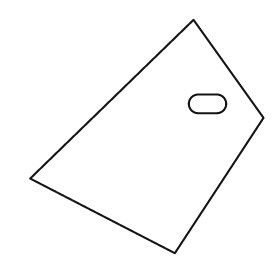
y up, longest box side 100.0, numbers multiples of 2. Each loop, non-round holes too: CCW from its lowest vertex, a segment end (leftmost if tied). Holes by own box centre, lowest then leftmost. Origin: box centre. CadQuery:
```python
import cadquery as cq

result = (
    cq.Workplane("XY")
    .moveTo(12.0, -50.0)
    .lineTo(50.0, 8.0)
    .lineTo(20.0, 50.0)
    .lineTo(-50.0, -18.0)
    .close()
    .moveTo(22.0, 10.0)
    .lineTo(30.0, 10.0)
    .threePointArc((34.0, 14.0), (30.0, 18.0))
    .lineTo(22.0, 18.0)
    .threePointArc((18.0, 14.0), (22.0, 10.0))
    .close()
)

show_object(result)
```